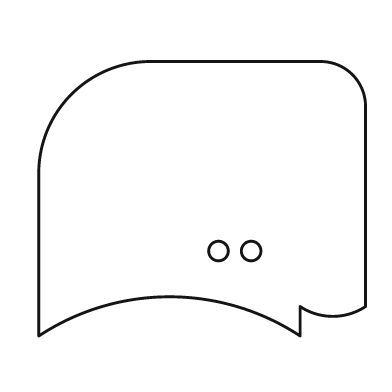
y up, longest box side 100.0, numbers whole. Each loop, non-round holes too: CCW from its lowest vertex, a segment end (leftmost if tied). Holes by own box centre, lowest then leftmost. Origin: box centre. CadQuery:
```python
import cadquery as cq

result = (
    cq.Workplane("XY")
    .moveTo(-50.0, -42.0)
    .threePointArc((-10.0, -30.0), (30.0, -42.0))
    .lineTo(30.0, -33.0)
    .threePointArc((40.0, -36.0), (50.0, -33.0))
    .lineTo(50.0, 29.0)
    .threePointArc((46.0, 38.0), (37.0, 42.0))
    .lineTo(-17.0, 42.0)
    .threePointArc((-40.0, 32.0), (-50.0, 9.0))
    .close()
    .moveTo(5.0, -16.0)
    .circle(3.0)
    .moveTo(15.0, -16.0)
    .circle(3.0)
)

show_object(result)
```